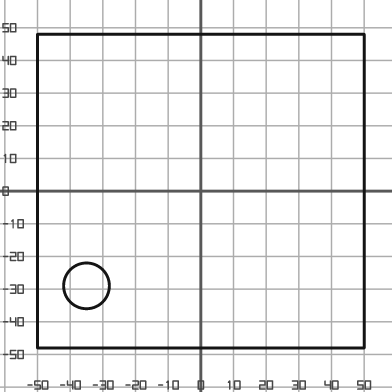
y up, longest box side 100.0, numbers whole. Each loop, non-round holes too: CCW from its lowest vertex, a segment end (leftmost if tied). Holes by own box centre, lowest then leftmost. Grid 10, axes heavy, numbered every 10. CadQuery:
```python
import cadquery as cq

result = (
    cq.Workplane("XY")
    .moveTo(-50.0, -48.0)
    .lineTo(50.0, -48.0)
    .lineTo(50.0, 48.0)
    .lineTo(-50.0, 48.0)
    .close()
    .moveTo(-35.0, -29.0)
    .circle(7.0)
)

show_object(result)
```